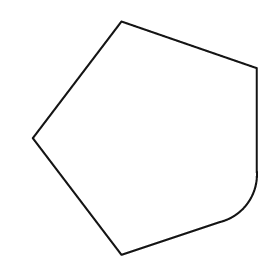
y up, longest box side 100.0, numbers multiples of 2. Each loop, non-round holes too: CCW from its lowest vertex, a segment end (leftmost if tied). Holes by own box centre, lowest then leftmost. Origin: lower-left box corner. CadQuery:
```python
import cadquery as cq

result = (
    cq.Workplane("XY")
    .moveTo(38.0, 0.0)
    .lineTo(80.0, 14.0)
    .threePointArc((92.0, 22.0), (96.0, 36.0))
    .lineTo(96.0, 80.0)
    .lineTo(38.0, 100.0)
    .lineTo(0.0, 50.0)
    .close()
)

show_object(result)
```